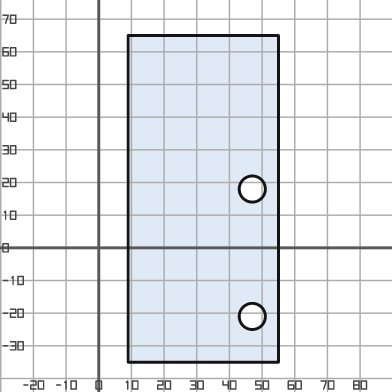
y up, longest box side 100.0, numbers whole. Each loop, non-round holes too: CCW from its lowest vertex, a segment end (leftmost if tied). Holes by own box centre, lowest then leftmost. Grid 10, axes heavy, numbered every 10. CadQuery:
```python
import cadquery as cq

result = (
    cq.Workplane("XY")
    .moveTo(9.0, -35.0)
    .lineTo(55.0, -35.0)
    .lineTo(55.0, 65.0)
    .lineTo(9.0, 65.0)
    .close()
    .moveTo(47.0, -21.0)
    .circle(4.0)
    .moveTo(47.0, 18.0)
    .circle(4.0)
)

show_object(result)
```